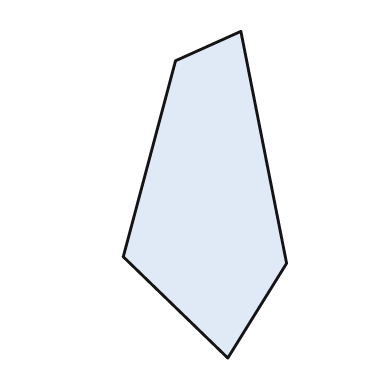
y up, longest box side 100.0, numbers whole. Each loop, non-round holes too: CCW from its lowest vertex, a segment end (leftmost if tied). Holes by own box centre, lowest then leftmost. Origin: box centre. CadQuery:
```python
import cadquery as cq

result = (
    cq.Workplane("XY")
    .moveTo(7.0, -50.0)
    .lineTo(25.0, -21.0)
    .lineTo(11.0, 50.0)
    .lineTo(-9.0, 41.0)
    .lineTo(-25.0, -19.0)
    .close()
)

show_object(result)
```